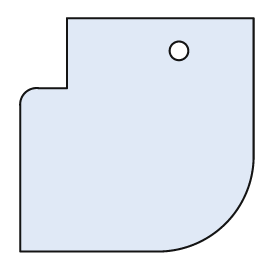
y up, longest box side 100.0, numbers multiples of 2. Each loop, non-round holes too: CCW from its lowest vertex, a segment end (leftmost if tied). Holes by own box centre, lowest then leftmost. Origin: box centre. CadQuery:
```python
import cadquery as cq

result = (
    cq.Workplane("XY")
    .moveTo(-50.0, -50.0)
    .lineTo(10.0, -50.0)
    .threePointArc((38.0, -38.0), (50.0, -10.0))
    .lineTo(50.0, 50.0)
    .lineTo(-30.0, 50.0)
    .lineTo(-30.0, 20.0)
    .lineTo(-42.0, 20.0)
    .threePointArc((-48.0, 18.0), (-50.0, 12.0))
    .close()
    .moveTo(18.0, 36.0)
    .circle(4.0)
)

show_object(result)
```